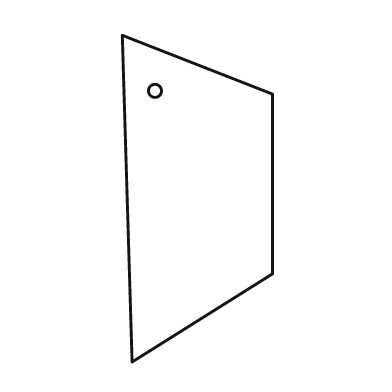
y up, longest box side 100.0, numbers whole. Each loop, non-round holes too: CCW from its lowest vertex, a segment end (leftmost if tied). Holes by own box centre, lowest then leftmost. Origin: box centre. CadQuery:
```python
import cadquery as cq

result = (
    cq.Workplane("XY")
    .moveTo(-20.0, -50.0)
    .lineTo(23.0, -23.0)
    .lineTo(23.0, 32.0)
    .lineTo(-23.0, 50.0)
    .close()
    .moveTo(-13.0, 33.0)
    .circle(2.0)
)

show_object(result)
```